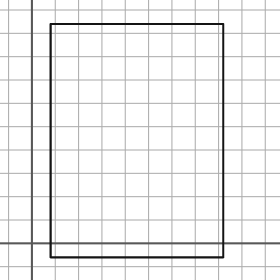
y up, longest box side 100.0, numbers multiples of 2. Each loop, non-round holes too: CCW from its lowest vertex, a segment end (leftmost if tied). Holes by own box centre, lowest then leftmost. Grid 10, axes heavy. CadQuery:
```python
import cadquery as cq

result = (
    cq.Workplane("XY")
    .moveTo(8.0, -6.0)
    .lineTo(82.0, -6.0)
    .lineTo(82.0, 94.0)
    .lineTo(8.0, 94.0)
    .close()
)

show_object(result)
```